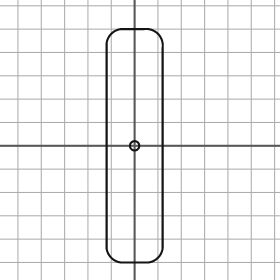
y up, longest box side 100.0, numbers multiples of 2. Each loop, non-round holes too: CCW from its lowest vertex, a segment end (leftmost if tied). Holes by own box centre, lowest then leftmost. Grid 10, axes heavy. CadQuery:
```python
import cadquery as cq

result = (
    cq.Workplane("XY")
    .moveTo(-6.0, -50.0)
    .lineTo(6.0, -50.0)
    .threePointArc((10.0, -48.0), (12.0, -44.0))
    .lineTo(12.0, 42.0)
    .threePointArc((10.0, 48.0), (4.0, 50.0))
    .lineTo(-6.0, 50.0)
    .threePointArc((-10.0, 48.0), (-12.0, 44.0))
    .lineTo(-12.0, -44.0)
    .threePointArc((-10.0, -48.0), (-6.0, -50.0))
    .close()
    .moveTo(0.0, 0.0)
    .circle(2.0)
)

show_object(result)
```